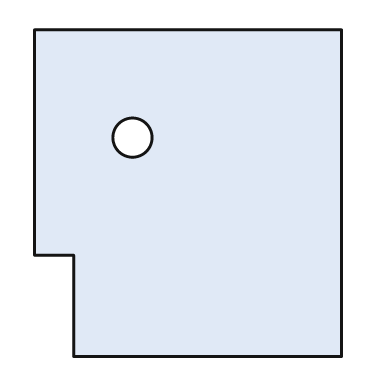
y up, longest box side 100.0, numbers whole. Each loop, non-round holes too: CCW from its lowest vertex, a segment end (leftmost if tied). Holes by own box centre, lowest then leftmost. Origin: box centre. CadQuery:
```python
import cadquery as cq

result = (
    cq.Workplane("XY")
    .moveTo(-35.0, -50.0)
    .lineTo(47.0, -50.0)
    .lineTo(47.0, 50.0)
    .lineTo(-47.0, 50.0)
    .lineTo(-47.0, -19.0)
    .lineTo(-35.0, -19.0)
    .close()
    .moveTo(-17.0, 17.0)
    .circle(6.0)
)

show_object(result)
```